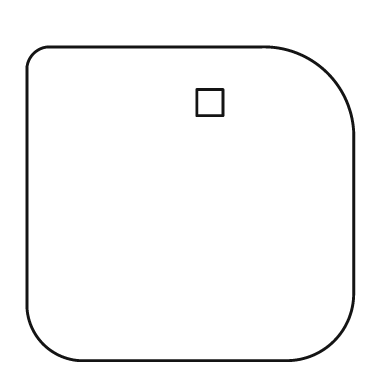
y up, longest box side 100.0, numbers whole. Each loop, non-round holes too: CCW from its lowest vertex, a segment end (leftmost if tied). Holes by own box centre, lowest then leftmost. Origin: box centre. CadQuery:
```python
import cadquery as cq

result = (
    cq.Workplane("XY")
    .moveTo(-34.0, -48.0)
    .lineTo(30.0, -48.0)
    .threePointArc((44.0, -42.0), (50.0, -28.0))
    .lineTo(50.0, 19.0)
    .threePointArc((42.0, 40.0), (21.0, 48.0))
    .lineTo(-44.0, 48.0)
    .threePointArc((-48.0, 46.0), (-50.0, 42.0))
    .lineTo(-50.0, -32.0)
    .threePointArc((-45.0, -43.0), (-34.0, -48.0))
    .close()
    .moveTo(2.0, 27.0)
    .lineTo(10.0, 27.0)
    .lineTo(10.0, 35.0)
    .lineTo(2.0, 35.0)
    .close()
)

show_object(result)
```